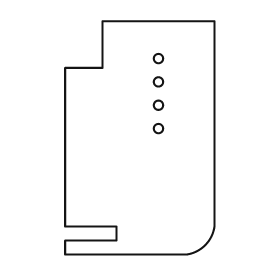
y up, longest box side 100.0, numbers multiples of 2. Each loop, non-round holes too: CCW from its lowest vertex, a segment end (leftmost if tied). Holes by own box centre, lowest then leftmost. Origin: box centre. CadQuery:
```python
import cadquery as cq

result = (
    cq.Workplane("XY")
    .moveTo(-32.0, -50.0)
    .lineTo(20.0, -50.0)
    .threePointArc((28.0, -46.0), (32.0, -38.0))
    .lineTo(32.0, 50.0)
    .lineTo(-16.0, 50.0)
    .lineTo(-16.0, 30.0)
    .lineTo(-32.0, 30.0)
    .lineTo(-32.0, -38.0)
    .lineTo(-10.0, -38.0)
    .lineTo(-10.0, -44.0)
    .lineTo(-32.0, -44.0)
    .close()
    .moveTo(8.0, 4.0)
    .circle(2.0)
    .moveTo(8.0, 14.0)
    .circle(2.0)
    .moveTo(8.0, 24.0)
    .circle(2.0)
    .moveTo(8.0, 34.0)
    .circle(2.0)
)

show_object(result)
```